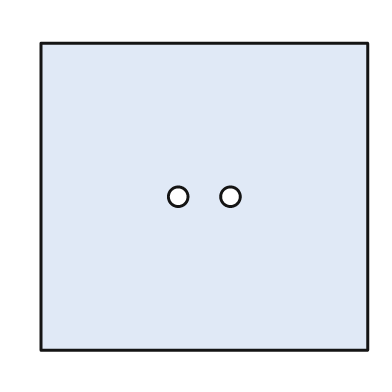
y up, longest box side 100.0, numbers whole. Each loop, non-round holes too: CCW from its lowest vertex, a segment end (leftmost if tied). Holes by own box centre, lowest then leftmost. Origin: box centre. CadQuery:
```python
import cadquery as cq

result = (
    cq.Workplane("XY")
    .moveTo(-50.0, -47.0)
    .lineTo(50.0, -47.0)
    .lineTo(50.0, 47.0)
    .lineTo(-50.0, 47.0)
    .close()
    .moveTo(-8.0, 0.0)
    .circle(3.0)
    .moveTo(8.0, 0.0)
    .circle(3.0)
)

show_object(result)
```